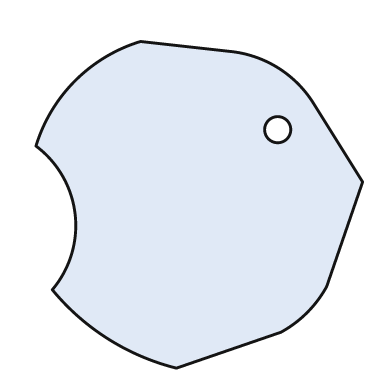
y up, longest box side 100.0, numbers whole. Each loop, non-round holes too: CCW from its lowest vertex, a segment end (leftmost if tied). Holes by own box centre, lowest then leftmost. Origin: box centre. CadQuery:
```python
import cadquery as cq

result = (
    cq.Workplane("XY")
    .moveTo(-7.0, -50.0)
    .lineTo(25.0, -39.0)
    .threePointArc((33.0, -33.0), (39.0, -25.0))
    .lineTo(50.0, 7.0)
    .lineTo(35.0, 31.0)
    .threePointArc((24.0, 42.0), (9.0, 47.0))
    .lineTo(-18.0, 50.0)
    .threePointArc((-38.0, 38.0), (-50.0, 18.0))
    .threePointArc((-38.0, -3.0), (-45.0, -26.0))
    .threePointArc((-28.0, -41.0), (-7.0, -50.0))
    .close()
    .moveTo(24.0, 23.0)
    .circle(4.0)
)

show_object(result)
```